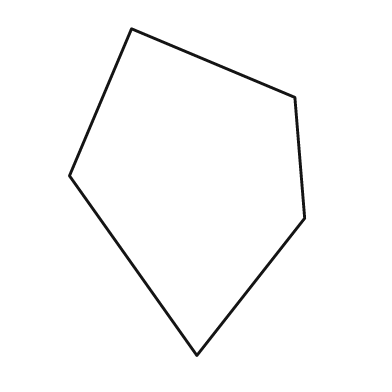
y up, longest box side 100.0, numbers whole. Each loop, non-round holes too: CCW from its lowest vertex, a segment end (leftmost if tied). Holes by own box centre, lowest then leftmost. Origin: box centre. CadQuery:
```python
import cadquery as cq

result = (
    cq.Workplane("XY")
    .moveTo(3.0, -50.0)
    .lineTo(36.0, -8.0)
    .lineTo(33.0, 29.0)
    .lineTo(-17.0, 50.0)
    .lineTo(-36.0, 5.0)
    .close()
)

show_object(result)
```